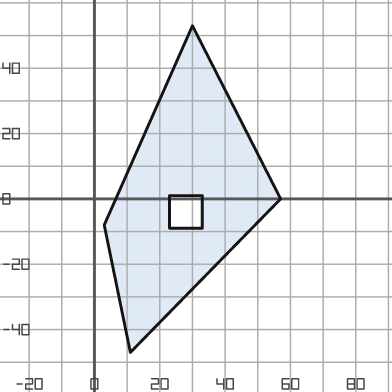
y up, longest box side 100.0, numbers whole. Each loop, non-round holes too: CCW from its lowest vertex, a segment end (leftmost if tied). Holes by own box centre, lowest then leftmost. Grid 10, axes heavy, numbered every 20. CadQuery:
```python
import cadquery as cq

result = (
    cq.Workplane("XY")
    .moveTo(11.0, -47.0)
    .lineTo(57.0, 0.0)
    .lineTo(30.0, 53.0)
    .lineTo(3.0, -8.0)
    .close()
    .moveTo(23.0, -9.0)
    .lineTo(33.0, -9.0)
    .lineTo(33.0, 1.0)
    .lineTo(23.0, 1.0)
    .close()
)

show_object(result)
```